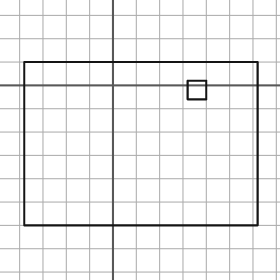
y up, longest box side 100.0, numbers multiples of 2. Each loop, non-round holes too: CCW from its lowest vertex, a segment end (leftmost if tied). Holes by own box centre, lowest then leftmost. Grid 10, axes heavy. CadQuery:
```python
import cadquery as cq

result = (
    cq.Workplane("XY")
    .moveTo(-38.0, -60.0)
    .lineTo(62.0, -60.0)
    .lineTo(62.0, 10.0)
    .lineTo(-38.0, 10.0)
    .close()
    .moveTo(32.0, -6.0)
    .lineTo(40.0, -6.0)
    .lineTo(40.0, 2.0)
    .lineTo(32.0, 2.0)
    .close()
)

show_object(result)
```